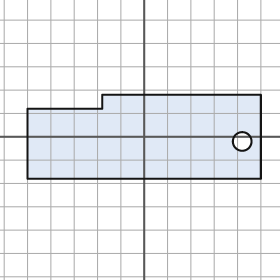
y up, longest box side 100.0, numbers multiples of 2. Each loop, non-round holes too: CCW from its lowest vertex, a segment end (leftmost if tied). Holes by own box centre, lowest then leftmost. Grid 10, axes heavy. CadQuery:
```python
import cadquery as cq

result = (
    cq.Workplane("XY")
    .moveTo(-50.0, -18.0)
    .lineTo(50.0, -18.0)
    .lineTo(50.0, 18.0)
    .lineTo(-18.0, 18.0)
    .lineTo(-18.0, 12.0)
    .lineTo(-50.0, 12.0)
    .close()
    .moveTo(42.0, -2.0)
    .circle(4.0)
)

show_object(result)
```